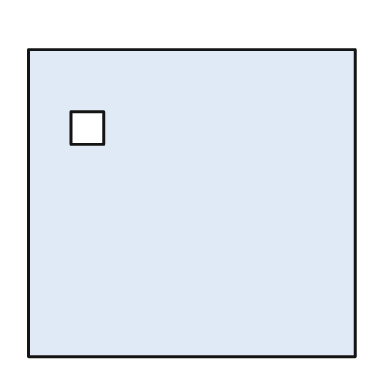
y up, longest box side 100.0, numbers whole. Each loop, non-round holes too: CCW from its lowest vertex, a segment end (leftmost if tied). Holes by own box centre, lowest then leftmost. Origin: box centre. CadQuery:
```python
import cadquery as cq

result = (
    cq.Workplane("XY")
    .moveTo(-50.0, -47.0)
    .lineTo(50.0, -47.0)
    .lineTo(50.0, 47.0)
    .lineTo(-50.0, 47.0)
    .close()
    .moveTo(-37.0, 18.0)
    .lineTo(-27.0, 18.0)
    .lineTo(-27.0, 28.0)
    .lineTo(-37.0, 28.0)
    .close()
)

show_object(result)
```